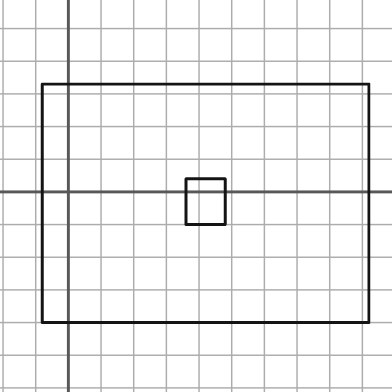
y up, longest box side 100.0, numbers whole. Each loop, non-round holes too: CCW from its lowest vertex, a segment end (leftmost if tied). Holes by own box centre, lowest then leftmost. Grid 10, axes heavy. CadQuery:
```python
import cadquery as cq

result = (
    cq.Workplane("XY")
    .moveTo(-8.0, -40.0)
    .lineTo(92.0, -40.0)
    .lineTo(92.0, 33.0)
    .lineTo(-8.0, 33.0)
    .close()
    .moveTo(36.0, -10.0)
    .lineTo(48.0, -10.0)
    .lineTo(48.0, 4.0)
    .lineTo(36.0, 4.0)
    .close()
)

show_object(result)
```